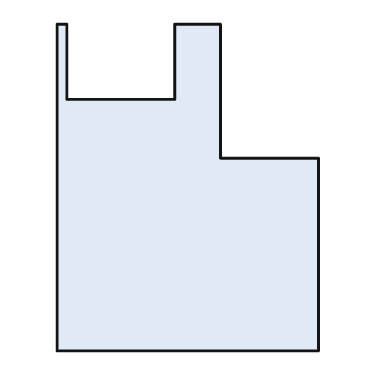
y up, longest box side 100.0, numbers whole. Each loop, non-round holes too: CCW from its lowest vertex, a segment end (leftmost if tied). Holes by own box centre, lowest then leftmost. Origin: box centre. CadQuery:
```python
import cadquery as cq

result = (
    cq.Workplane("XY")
    .moveTo(-40.0, -50.0)
    .lineTo(40.0, -50.0)
    .lineTo(40.0, 9.0)
    .lineTo(10.0, 9.0)
    .lineTo(10.0, 50.0)
    .lineTo(-4.0, 50.0)
    .lineTo(-4.0, 27.0)
    .lineTo(-37.0, 27.0)
    .lineTo(-37.0, 50.0)
    .lineTo(-40.0, 50.0)
    .close()
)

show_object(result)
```